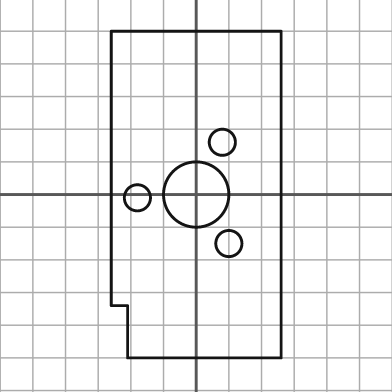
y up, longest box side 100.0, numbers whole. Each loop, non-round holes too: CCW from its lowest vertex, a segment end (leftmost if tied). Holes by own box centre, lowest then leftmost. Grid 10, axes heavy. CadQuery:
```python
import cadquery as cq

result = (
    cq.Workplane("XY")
    .moveTo(-21.0, -50.0)
    .lineTo(26.0, -50.0)
    .lineTo(26.0, 50.0)
    .lineTo(-26.0, 50.0)
    .lineTo(-26.0, -34.0)
    .lineTo(-21.0, -34.0)
    .close()
    .moveTo(10.0, -15.0)
    .circle(4.0)
    .moveTo(-18.0, -1.0)
    .circle(4.0)
    .moveTo(0.0, 0.0)
    .circle(10.0)
    .moveTo(8.0, 16.0)
    .circle(4.0)
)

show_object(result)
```